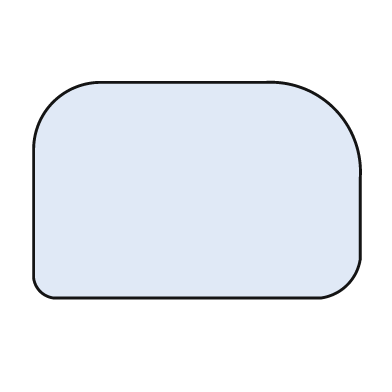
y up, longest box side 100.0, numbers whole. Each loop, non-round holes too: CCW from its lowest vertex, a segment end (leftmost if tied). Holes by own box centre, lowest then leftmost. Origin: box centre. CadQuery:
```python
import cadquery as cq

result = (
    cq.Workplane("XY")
    .moveTo(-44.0, -33.0)
    .lineTo(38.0, -33.0)
    .threePointArc((46.0, -29.0), (50.0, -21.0))
    .lineTo(50.0, 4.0)
    .threePointArc((42.0, 25.0), (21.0, 33.0))
    .lineTo(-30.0, 33.0)
    .threePointArc((-44.0, 27.0), (-50.0, 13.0))
    .lineTo(-50.0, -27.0)
    .threePointArc((-48.0, -31.0), (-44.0, -33.0))
    .close()
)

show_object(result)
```